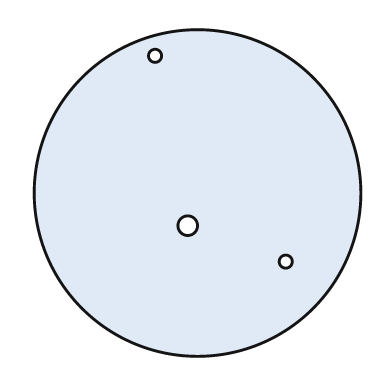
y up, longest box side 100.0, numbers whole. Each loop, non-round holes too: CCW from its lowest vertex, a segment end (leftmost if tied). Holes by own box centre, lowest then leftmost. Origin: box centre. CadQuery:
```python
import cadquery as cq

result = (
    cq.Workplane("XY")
    .moveTo(0.0, 0.0)
    .circle(50.0)
    .moveTo(27.0, -21.0)
    .circle(2.0)
    .moveTo(-3.0, -10.0)
    .circle(3.0)
    .moveTo(-13.0, 42.0)
    .circle(2.0)
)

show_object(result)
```